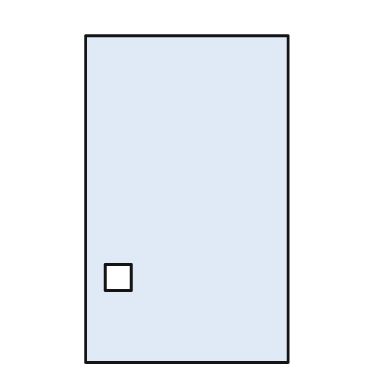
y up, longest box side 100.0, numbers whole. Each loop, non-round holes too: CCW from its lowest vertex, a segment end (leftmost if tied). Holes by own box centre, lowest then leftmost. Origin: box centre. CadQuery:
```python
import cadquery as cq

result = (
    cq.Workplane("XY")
    .moveTo(-31.0, -50.0)
    .lineTo(31.0, -50.0)
    .lineTo(31.0, 50.0)
    .lineTo(-31.0, 50.0)
    .close()
    .moveTo(-25.0, -28.0)
    .lineTo(-17.0, -28.0)
    .lineTo(-17.0, -20.0)
    .lineTo(-25.0, -20.0)
    .close()
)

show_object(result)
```